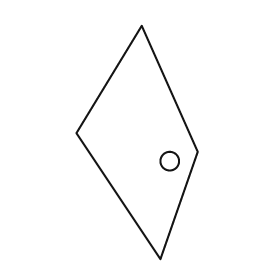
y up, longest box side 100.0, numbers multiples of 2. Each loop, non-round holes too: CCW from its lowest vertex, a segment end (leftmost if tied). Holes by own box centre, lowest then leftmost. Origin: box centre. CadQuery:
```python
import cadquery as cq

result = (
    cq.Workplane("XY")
    .moveTo(10.0, -50.0)
    .lineTo(26.0, -4.0)
    .lineTo(2.0, 50.0)
    .lineTo(-26.0, 4.0)
    .close()
    .moveTo(14.0, -8.0)
    .circle(4.0)
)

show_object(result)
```